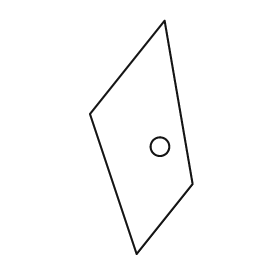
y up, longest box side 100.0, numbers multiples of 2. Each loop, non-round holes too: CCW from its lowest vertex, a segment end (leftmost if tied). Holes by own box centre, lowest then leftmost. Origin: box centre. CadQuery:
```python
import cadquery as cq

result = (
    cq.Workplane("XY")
    .moveTo(-2.0, -50.0)
    .lineTo(22.0, -20.0)
    .lineTo(10.0, 50.0)
    .lineTo(-22.0, 10.0)
    .close()
    .moveTo(8.0, -4.0)
    .circle(4.0)
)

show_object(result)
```